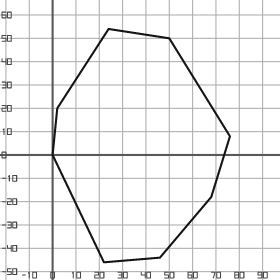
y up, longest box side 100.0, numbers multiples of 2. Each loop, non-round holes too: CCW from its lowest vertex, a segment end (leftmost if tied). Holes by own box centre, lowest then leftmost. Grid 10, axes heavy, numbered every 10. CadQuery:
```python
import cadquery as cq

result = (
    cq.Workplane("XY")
    .moveTo(22.0, -46.0)
    .lineTo(46.0, -44.0)
    .lineTo(68.0, -18.0)
    .lineTo(76.0, 8.0)
    .lineTo(50.0, 50.0)
    .lineTo(24.0, 54.0)
    .lineTo(2.0, 20.0)
    .lineTo(0.0, 0.0)
    .close()
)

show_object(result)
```